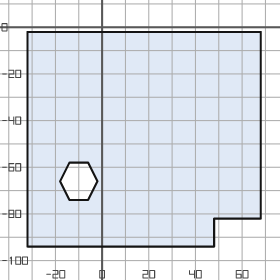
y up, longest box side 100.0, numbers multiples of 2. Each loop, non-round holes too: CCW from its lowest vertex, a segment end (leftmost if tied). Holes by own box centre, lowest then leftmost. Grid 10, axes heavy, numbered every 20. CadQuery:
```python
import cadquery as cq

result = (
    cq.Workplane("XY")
    .moveTo(-32.0, -94.0)
    .lineTo(48.0, -94.0)
    .lineTo(48.0, -82.0)
    .lineTo(68.0, -82.0)
    .lineTo(68.0, -2.0)
    .lineTo(-32.0, -2.0)
    .close()
    .moveTo(-14.0, -74.0)
    .lineTo(-6.0, -74.0)
    .lineTo(-2.0, -66.0)
    .lineTo(-6.0, -58.0)
    .lineTo(-14.0, -58.0)
    .lineTo(-18.0, -66.0)
    .close()
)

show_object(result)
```